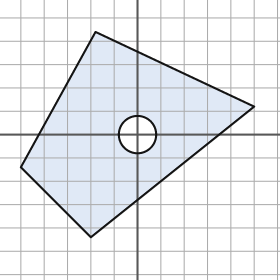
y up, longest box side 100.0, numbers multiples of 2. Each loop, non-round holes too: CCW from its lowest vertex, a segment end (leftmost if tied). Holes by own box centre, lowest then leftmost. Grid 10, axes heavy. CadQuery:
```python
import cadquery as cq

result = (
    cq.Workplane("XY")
    .moveTo(-20.0, -44.0)
    .lineTo(50.0, 12.0)
    .lineTo(-18.0, 44.0)
    .lineTo(-50.0, -14.0)
    .close()
    .moveTo(0.0, 0.0)
    .circle(8.0)
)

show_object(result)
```